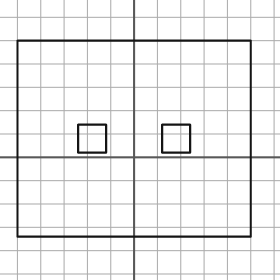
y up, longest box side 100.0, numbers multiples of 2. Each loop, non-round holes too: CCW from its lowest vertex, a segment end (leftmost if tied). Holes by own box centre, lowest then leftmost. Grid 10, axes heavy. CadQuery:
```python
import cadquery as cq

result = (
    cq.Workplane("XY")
    .moveTo(-50.0, -34.0)
    .lineTo(50.0, -34.0)
    .lineTo(50.0, 50.0)
    .lineTo(-50.0, 50.0)
    .close()
    .moveTo(-24.0, 2.0)
    .lineTo(-12.0, 2.0)
    .lineTo(-12.0, 14.0)
    .lineTo(-24.0, 14.0)
    .close()
    .moveTo(12.0, 2.0)
    .lineTo(24.0, 2.0)
    .lineTo(24.0, 14.0)
    .lineTo(12.0, 14.0)
    .close()
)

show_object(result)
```